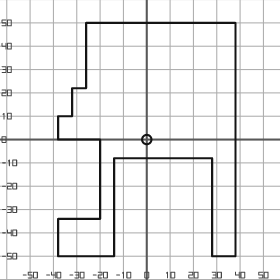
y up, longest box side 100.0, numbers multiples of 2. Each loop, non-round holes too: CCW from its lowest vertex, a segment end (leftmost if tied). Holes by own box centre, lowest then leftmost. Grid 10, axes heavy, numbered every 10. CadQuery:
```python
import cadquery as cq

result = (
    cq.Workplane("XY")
    .moveTo(-38.0, -50.0)
    .lineTo(-14.0, -50.0)
    .lineTo(-14.0, -8.0)
    .lineTo(28.0, -8.0)
    .lineTo(28.0, -50.0)
    .lineTo(38.0, -50.0)
    .lineTo(38.0, 50.0)
    .lineTo(-26.0, 50.0)
    .lineTo(-26.0, 22.0)
    .lineTo(-32.0, 22.0)
    .lineTo(-32.0, 10.0)
    .lineTo(-38.0, 10.0)
    .lineTo(-38.0, 0.0)
    .lineTo(-20.0, 0.0)
    .lineTo(-20.0, -34.0)
    .lineTo(-38.0, -34.0)
    .close()
    .moveTo(0.0, 0.0)
    .circle(2.0)
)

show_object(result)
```